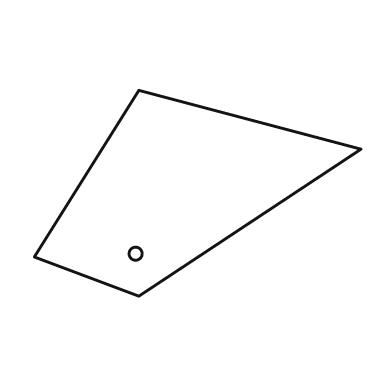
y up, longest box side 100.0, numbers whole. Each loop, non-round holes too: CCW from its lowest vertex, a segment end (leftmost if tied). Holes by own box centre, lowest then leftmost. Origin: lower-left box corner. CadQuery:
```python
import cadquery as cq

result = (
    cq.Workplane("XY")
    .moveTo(32.0, 0.0)
    .lineTo(100.0, 45.0)
    .lineTo(32.0, 63.0)
    .lineTo(0.0, 12.0)
    .close()
    .moveTo(31.0, 13.0)
    .circle(2.0)
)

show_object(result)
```